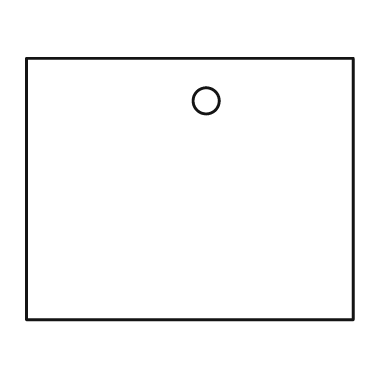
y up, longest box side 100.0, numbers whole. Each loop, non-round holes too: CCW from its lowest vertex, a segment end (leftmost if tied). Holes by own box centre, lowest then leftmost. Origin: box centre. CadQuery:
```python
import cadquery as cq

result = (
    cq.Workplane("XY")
    .moveTo(-50.0, -40.0)
    .lineTo(50.0, -40.0)
    .lineTo(50.0, 40.0)
    .lineTo(-50.0, 40.0)
    .close()
    .moveTo(5.0, 27.0)
    .circle(4.0)
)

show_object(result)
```